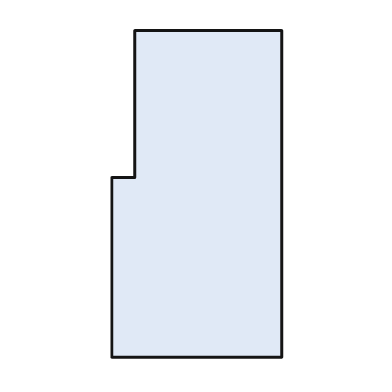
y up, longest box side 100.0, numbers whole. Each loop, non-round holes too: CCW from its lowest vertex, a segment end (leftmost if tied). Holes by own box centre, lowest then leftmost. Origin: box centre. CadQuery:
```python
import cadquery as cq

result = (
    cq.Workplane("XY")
    .moveTo(-26.0, -50.0)
    .lineTo(26.0, -50.0)
    .lineTo(26.0, 50.0)
    .lineTo(-19.0, 50.0)
    .lineTo(-19.0, 5.0)
    .lineTo(-26.0, 5.0)
    .close()
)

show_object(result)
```